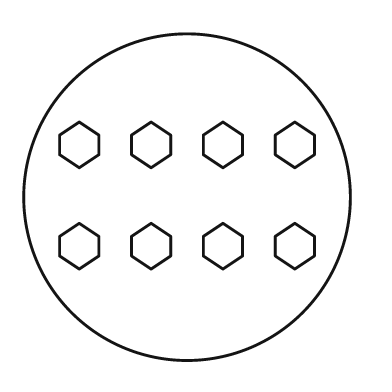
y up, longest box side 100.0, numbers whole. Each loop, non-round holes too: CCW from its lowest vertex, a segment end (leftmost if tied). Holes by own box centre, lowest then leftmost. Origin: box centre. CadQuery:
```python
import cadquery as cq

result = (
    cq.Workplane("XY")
    .moveTo(0.0, 0.0)
    .circle(50.0)
    .moveTo(-33.0, -22.0)
    .lineTo(-27.0, -18.0)
    .lineTo(-27.0, -12.0)
    .lineTo(-33.0, -8.0)
    .lineTo(-39.0, -12.0)
    .lineTo(-39.0, -18.0)
    .close()
    .moveTo(-11.0, -22.0)
    .lineTo(-5.0, -18.0)
    .lineTo(-5.0, -12.0)
    .lineTo(-11.0, -8.0)
    .lineTo(-17.0, -12.0)
    .lineTo(-17.0, -18.0)
    .close()
    .moveTo(11.0, -22.0)
    .lineTo(17.0, -18.0)
    .lineTo(17.0, -12.0)
    .lineTo(11.0, -8.0)
    .lineTo(5.0, -12.0)
    .lineTo(5.0, -18.0)
    .close()
    .moveTo(33.0, -22.0)
    .lineTo(39.0, -18.0)
    .lineTo(39.0, -12.0)
    .lineTo(33.0, -8.0)
    .lineTo(27.0, -12.0)
    .lineTo(27.0, -18.0)
    .close()
    .moveTo(-33.0, 9.0)
    .lineTo(-27.0, 13.0)
    .lineTo(-27.0, 19.0)
    .lineTo(-33.0, 23.0)
    .lineTo(-39.0, 19.0)
    .lineTo(-39.0, 13.0)
    .close()
    .moveTo(-11.0, 9.0)
    .lineTo(-5.0, 13.0)
    .lineTo(-5.0, 19.0)
    .lineTo(-11.0, 23.0)
    .lineTo(-17.0, 19.0)
    .lineTo(-17.0, 13.0)
    .close()
    .moveTo(11.0, 9.0)
    .lineTo(17.0, 13.0)
    .lineTo(17.0, 19.0)
    .lineTo(11.0, 23.0)
    .lineTo(5.0, 19.0)
    .lineTo(5.0, 13.0)
    .close()
    .moveTo(33.0, 9.0)
    .lineTo(39.0, 13.0)
    .lineTo(39.0, 19.0)
    .lineTo(33.0, 23.0)
    .lineTo(27.0, 19.0)
    .lineTo(27.0, 13.0)
    .close()
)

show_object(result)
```